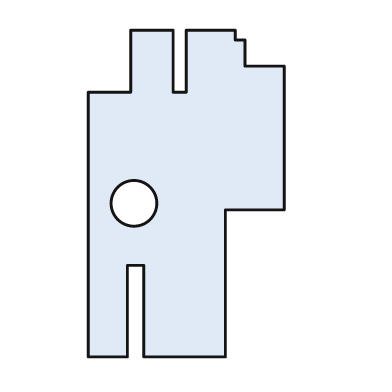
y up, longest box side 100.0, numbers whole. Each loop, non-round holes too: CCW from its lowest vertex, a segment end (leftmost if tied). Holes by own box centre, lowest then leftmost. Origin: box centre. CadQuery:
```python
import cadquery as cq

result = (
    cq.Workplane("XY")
    .moveTo(-30.0, -50.0)
    .lineTo(-18.0, -50.0)
    .lineTo(-18.0, -22.0)
    .lineTo(-13.0, -22.0)
    .lineTo(-13.0, -50.0)
    .lineTo(12.0, -50.0)
    .lineTo(12.0, -5.0)
    .lineTo(30.0, -5.0)
    .lineTo(30.0, 39.0)
    .lineTo(18.0, 39.0)
    .lineTo(18.0, 47.0)
    .lineTo(15.0, 47.0)
    .lineTo(15.0, 50.0)
    .lineTo(0.0, 50.0)
    .lineTo(0.0, 31.0)
    .lineTo(-4.0, 31.0)
    .lineTo(-4.0, 50.0)
    .lineTo(-17.0, 50.0)
    .lineTo(-17.0, 31.0)
    .lineTo(-30.0, 31.0)
    .close()
    .moveTo(-16.0, -3.0)
    .circle(7.0)
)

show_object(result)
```